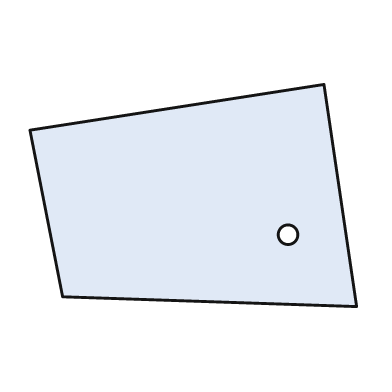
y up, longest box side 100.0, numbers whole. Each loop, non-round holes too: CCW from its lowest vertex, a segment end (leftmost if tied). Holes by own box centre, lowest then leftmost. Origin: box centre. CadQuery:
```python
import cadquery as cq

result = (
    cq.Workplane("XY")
    .moveTo(50.0, -34.0)
    .lineTo(40.0, 34.0)
    .lineTo(-50.0, 20.0)
    .lineTo(-40.0, -31.0)
    .close()
    .moveTo(29.0, -12.0)
    .circle(3.0)
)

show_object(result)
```